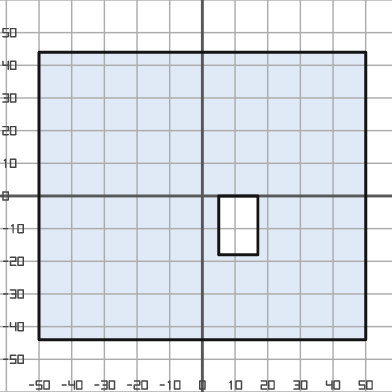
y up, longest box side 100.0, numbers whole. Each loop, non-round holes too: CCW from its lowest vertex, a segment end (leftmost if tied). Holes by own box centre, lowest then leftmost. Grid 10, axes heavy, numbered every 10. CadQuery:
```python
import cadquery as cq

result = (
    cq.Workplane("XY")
    .moveTo(-50.0, -44.0)
    .lineTo(50.0, -44.0)
    .lineTo(50.0, 44.0)
    .lineTo(-50.0, 44.0)
    .close()
    .moveTo(5.0, -18.0)
    .lineTo(17.0, -18.0)
    .lineTo(17.0, 0.0)
    .lineTo(5.0, 0.0)
    .close()
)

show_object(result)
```